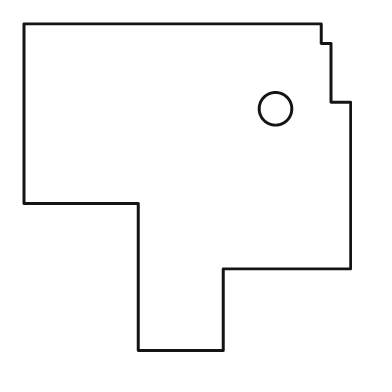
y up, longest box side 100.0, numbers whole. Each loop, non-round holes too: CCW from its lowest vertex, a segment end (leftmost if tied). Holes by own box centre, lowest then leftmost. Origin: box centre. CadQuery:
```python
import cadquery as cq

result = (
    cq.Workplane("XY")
    .moveTo(-15.0, -50.0)
    .lineTo(11.0, -50.0)
    .lineTo(11.0, -25.0)
    .lineTo(50.0, -25.0)
    .lineTo(50.0, 26.0)
    .lineTo(44.0, 26.0)
    .lineTo(44.0, 44.0)
    .lineTo(41.0, 44.0)
    .lineTo(41.0, 50.0)
    .lineTo(-50.0, 50.0)
    .lineTo(-50.0, -5.0)
    .lineTo(-15.0, -5.0)
    .close()
    .moveTo(27.0, 24.0)
    .circle(5.0)
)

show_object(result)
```